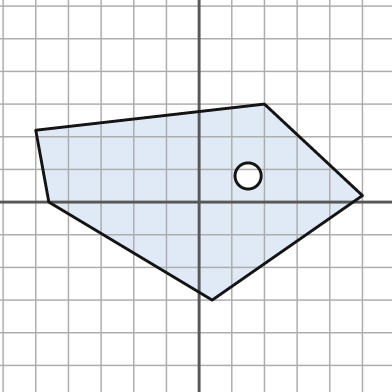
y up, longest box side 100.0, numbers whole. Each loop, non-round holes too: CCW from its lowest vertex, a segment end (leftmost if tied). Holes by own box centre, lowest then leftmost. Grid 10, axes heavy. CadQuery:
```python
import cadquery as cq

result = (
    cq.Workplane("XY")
    .moveTo(4.0, -30.0)
    .lineTo(50.0, 2.0)
    .lineTo(20.0, 30.0)
    .lineTo(-50.0, 22.0)
    .lineTo(-46.0, 0.0)
    .close()
    .moveTo(15.0, 8.0)
    .circle(4.0)
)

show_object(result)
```